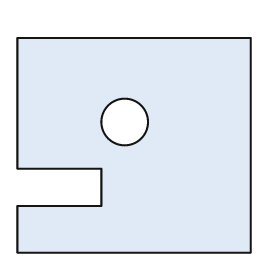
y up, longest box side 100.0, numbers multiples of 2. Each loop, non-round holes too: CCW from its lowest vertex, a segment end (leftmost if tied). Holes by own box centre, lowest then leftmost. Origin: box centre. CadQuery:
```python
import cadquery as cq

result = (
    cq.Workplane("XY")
    .moveTo(-50.0, -46.0)
    .lineTo(50.0, -46.0)
    .lineTo(50.0, 46.0)
    .lineTo(-50.0, 46.0)
    .lineTo(-50.0, -10.0)
    .lineTo(-14.0, -10.0)
    .lineTo(-14.0, -26.0)
    .lineTo(-50.0, -26.0)
    .close()
    .moveTo(-4.0, 10.0)
    .circle(10.0)
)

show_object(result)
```